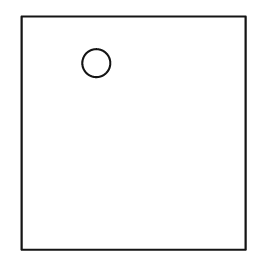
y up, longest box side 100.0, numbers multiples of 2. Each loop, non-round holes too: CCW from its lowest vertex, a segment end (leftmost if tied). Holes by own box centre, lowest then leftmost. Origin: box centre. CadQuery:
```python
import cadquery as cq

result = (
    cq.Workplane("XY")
    .moveTo(-48.0, -50.0)
    .lineTo(48.0, -50.0)
    .lineTo(48.0, 50.0)
    .lineTo(-48.0, 50.0)
    .close()
    .moveTo(-16.0, 30.0)
    .circle(6.0)
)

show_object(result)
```